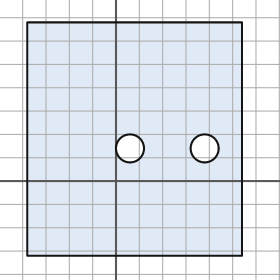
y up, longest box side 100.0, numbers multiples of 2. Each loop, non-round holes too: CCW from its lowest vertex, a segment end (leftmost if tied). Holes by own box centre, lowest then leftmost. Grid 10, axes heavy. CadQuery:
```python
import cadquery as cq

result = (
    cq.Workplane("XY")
    .moveTo(-38.0, -32.0)
    .lineTo(54.0, -32.0)
    .lineTo(54.0, 68.0)
    .lineTo(-38.0, 68.0)
    .close()
    .moveTo(6.0, 14.0)
    .circle(6.0)
    .moveTo(38.0, 14.0)
    .circle(6.0)
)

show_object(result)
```